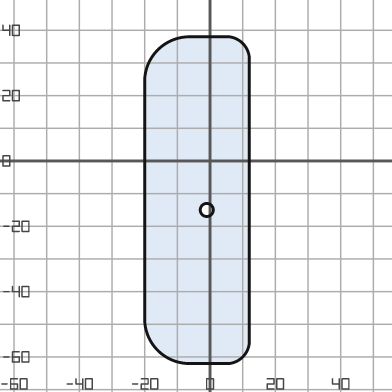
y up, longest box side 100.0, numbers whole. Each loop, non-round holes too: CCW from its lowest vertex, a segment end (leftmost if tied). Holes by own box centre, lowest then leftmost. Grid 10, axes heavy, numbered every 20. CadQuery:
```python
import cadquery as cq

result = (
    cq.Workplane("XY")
    .moveTo(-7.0, -62.0)
    .lineTo(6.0, -62.0)
    .threePointArc((10.0, -60.0), (12.0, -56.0))
    .lineTo(12.0, 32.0)
    .threePointArc((10.0, 36.0), (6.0, 38.0))
    .lineTo(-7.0, 38.0)
    .threePointArc((-16.0, 34.0), (-20.0, 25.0))
    .lineTo(-20.0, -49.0)
    .threePointArc((-16.0, -58.0), (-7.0, -62.0))
    .close()
    .moveTo(-1.0, -15.0)
    .circle(2.0)
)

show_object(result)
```